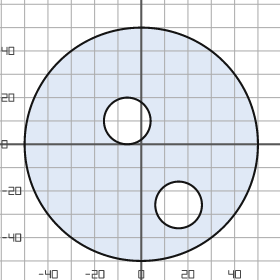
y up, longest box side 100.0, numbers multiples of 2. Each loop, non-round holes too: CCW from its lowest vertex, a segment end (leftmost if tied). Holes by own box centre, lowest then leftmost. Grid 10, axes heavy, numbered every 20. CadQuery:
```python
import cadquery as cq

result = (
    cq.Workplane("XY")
    .moveTo(0.0, 0.0)
    .circle(50.0)
    .moveTo(16.0, -26.0)
    .circle(10.0)
    .moveTo(-6.0, 10.0)
    .circle(10.0)
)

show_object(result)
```